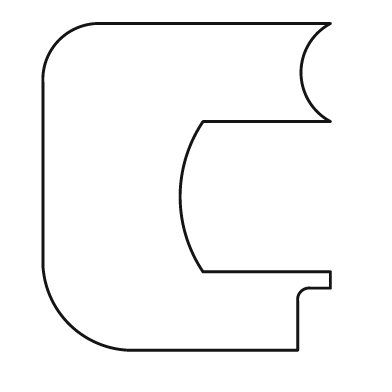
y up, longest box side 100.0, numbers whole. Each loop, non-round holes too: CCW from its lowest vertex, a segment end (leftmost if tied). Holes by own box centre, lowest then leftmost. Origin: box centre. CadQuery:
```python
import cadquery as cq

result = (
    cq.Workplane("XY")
    .moveTo(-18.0, -50.0)
    .lineTo(34.0, -50.0)
    .lineTo(34.0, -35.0)
    .threePointArc((35.0, -32.0), (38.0, -31.0))
    .lineTo(44.0, -31.0)
    .lineTo(44.0, -26.0)
    .lineTo(5.0, -26.0)
    .threePointArc((-2.0, -3.0), (5.0, 20.0))
    .lineTo(44.0, 20.0)
    .threePointArc((35.0, 35.0), (44.0, 50.0))
    .lineTo(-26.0, 50.0)
    .threePointArc((-39.0, 45.0), (-44.0, 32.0))
    .lineTo(-44.0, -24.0)
    .threePointArc((-36.0, -42.0), (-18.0, -50.0))
    .close()
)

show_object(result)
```